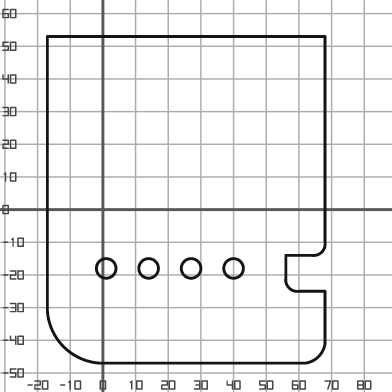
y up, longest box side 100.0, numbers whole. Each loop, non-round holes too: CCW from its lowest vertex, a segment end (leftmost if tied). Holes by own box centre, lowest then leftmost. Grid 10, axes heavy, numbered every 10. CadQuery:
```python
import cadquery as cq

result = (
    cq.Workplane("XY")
    .moveTo(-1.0, -47.0)
    .lineTo(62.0, -47.0)
    .threePointArc((66.0, -45.0), (68.0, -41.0))
    .lineTo(68.0, -25.0)
    .lineTo(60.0, -25.0)
    .threePointArc((57.0, -24.0), (56.0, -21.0))
    .lineTo(56.0, -14.0)
    .lineTo(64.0, -14.0)
    .threePointArc((67.0, -13.0), (68.0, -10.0))
    .lineTo(68.0, 53.0)
    .lineTo(-17.0, 53.0)
    .lineTo(-17.0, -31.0)
    .threePointArc((-12.0, -42.0), (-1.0, -47.0))
    .close()
    .moveTo(1.0, -18.0)
    .circle(3.0)
    .moveTo(14.0, -18.0)
    .circle(3.0)
    .moveTo(27.0, -18.0)
    .circle(3.0)
    .moveTo(40.0, -18.0)
    .circle(3.0)
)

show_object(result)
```